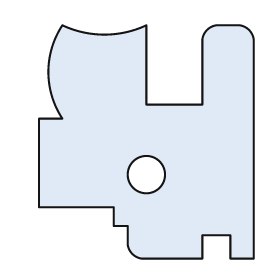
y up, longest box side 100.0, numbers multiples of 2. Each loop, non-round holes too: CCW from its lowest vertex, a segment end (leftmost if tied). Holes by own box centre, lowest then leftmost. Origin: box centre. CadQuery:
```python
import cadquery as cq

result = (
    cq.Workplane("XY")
    .moveTo(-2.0, -50.0)
    .lineTo(24.0, -50.0)
    .lineTo(24.0, -40.0)
    .lineTo(36.0, -40.0)
    .lineTo(36.0, -50.0)
    .lineTo(46.0, -50.0)
    .lineTo(46.0, 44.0)
    .threePointArc((44.0, 48.0), (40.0, 50.0))
    .lineTo(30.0, 50.0)
    .threePointArc((26.0, 48.0), (24.0, 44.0))
    .lineTo(24.0, 16.0)
    .lineTo(0.0, 16.0)
    .lineTo(0.0, 50.0)
    .threePointArc((-18.0, 46.0), (-36.0, 50.0))
    .threePointArc((-42.0, 30.0), (-36.0, 10.0))
    .lineTo(-46.0, 10.0)
    .lineTo(-46.0, -28.0)
    .lineTo(-14.0, -28.0)
    .lineTo(-14.0, -36.0)
    .lineTo(-8.0, -36.0)
    .lineTo(-8.0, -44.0)
    .threePointArc((-6.0, -48.0), (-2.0, -50.0))
    .close()
    .moveTo(0.0, -14.0)
    .circle(8.0)
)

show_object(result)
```